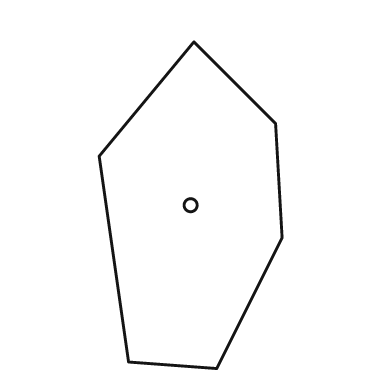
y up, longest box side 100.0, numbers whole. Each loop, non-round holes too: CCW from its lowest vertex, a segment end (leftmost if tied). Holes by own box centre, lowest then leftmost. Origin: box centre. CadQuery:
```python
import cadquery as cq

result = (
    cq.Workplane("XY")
    .moveTo(8.0, -50.0)
    .lineTo(28.0, -10.0)
    .lineTo(26.0, 25.0)
    .lineTo(1.0, 50.0)
    .lineTo(-28.0, 15.0)
    .lineTo(-19.0, -48.0)
    .close()
    .moveTo(0.0, 0.0)
    .circle(2.0)
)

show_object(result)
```